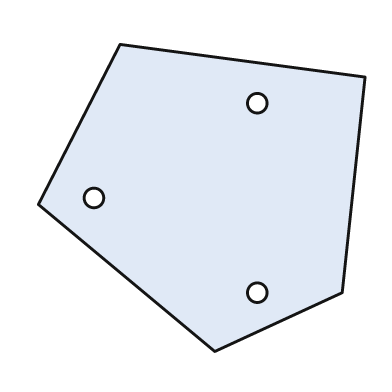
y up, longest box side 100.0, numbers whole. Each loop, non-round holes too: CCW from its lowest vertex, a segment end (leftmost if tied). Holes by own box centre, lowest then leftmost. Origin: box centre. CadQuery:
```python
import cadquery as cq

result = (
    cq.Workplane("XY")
    .moveTo(4.0, -47.0)
    .lineTo(43.0, -29.0)
    .lineTo(50.0, 37.0)
    .lineTo(-25.0, 47.0)
    .lineTo(-50.0, -2.0)
    .close()
    .moveTo(17.0, -29.0)
    .circle(3.0)
    .moveTo(-33.0, 0.0)
    .circle(3.0)
    .moveTo(17.0, 29.0)
    .circle(3.0)
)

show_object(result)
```